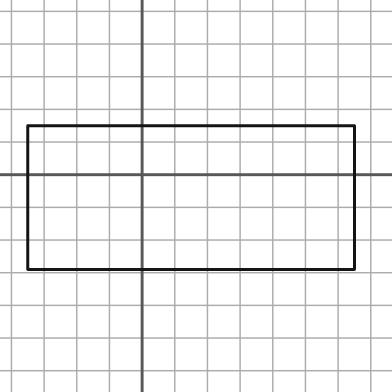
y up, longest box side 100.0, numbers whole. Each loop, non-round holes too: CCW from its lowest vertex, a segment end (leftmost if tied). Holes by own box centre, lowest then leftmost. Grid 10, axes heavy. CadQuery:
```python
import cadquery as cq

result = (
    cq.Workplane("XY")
    .moveTo(-35.0, -29.0)
    .lineTo(65.0, -29.0)
    .lineTo(65.0, 15.0)
    .lineTo(-35.0, 15.0)
    .close()
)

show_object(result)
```